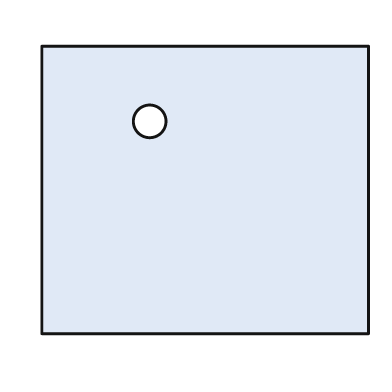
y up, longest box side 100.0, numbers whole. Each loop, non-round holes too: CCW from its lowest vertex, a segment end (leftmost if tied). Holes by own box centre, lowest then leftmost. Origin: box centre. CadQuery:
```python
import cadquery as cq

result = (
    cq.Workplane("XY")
    .moveTo(-50.0, -44.0)
    .lineTo(50.0, -44.0)
    .lineTo(50.0, 44.0)
    .lineTo(-50.0, 44.0)
    .close()
    .moveTo(-17.0, 21.0)
    .circle(5.0)
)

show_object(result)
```